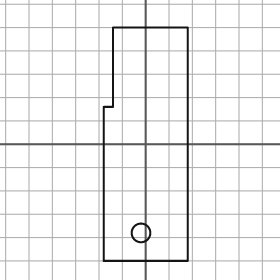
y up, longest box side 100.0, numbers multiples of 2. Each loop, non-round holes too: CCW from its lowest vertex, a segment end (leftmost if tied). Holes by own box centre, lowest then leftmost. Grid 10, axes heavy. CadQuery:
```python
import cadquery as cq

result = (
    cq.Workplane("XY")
    .moveTo(-18.0, -50.0)
    .lineTo(18.0, -50.0)
    .lineTo(18.0, 50.0)
    .lineTo(-14.0, 50.0)
    .lineTo(-14.0, 16.0)
    .lineTo(-18.0, 16.0)
    .close()
    .moveTo(-2.0, -38.0)
    .circle(4.0)
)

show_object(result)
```